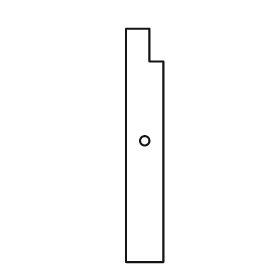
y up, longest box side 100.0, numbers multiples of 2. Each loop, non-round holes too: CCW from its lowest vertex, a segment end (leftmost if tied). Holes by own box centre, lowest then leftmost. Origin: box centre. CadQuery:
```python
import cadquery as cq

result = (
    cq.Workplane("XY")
    .moveTo(-8.0, -50.0)
    .lineTo(8.0, -50.0)
    .lineTo(8.0, 36.0)
    .lineTo(2.0, 36.0)
    .lineTo(2.0, 50.0)
    .lineTo(-8.0, 50.0)
    .close()
    .moveTo(0.0, 2.0)
    .circle(2.0)
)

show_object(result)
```